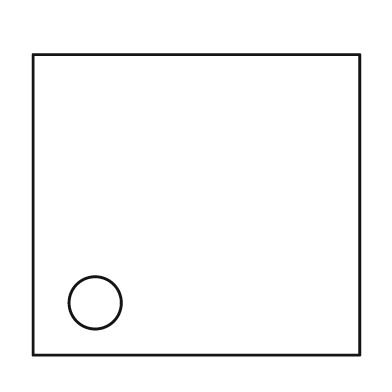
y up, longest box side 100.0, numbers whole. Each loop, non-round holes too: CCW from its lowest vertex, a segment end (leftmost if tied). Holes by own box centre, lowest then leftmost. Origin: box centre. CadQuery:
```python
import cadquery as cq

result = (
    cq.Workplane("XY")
    .moveTo(-50.0, -46.0)
    .lineTo(50.0, -46.0)
    .lineTo(50.0, 46.0)
    .lineTo(-50.0, 46.0)
    .close()
    .moveTo(-31.0, -30.0)
    .circle(8.0)
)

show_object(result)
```